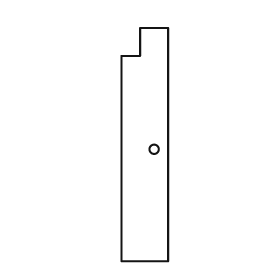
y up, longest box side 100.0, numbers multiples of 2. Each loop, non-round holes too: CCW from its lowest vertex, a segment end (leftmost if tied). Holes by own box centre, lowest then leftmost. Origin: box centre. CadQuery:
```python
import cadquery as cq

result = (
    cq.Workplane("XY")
    .moveTo(-10.0, -50.0)
    .lineTo(10.0, -50.0)
    .lineTo(10.0, 50.0)
    .lineTo(-2.0, 50.0)
    .lineTo(-2.0, 38.0)
    .lineTo(-10.0, 38.0)
    .close()
    .moveTo(4.0, -2.0)
    .circle(2.0)
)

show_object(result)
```